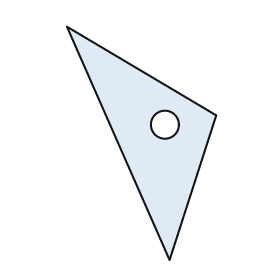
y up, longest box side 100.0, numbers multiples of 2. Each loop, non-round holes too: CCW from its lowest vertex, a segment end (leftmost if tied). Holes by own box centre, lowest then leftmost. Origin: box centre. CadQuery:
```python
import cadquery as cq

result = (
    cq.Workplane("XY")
    .moveTo(12.0, -50.0)
    .lineTo(32.0, 12.0)
    .lineTo(-32.0, 50.0)
    .close()
    .moveTo(10.0, 8.0)
    .circle(6.0)
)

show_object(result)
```